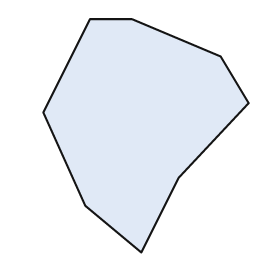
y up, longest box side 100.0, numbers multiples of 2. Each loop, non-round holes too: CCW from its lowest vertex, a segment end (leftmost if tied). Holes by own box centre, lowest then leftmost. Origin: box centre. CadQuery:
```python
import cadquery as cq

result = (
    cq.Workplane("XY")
    .moveTo(-2.0, -50.0)
    .lineTo(14.0, -18.0)
    .lineTo(44.0, 14.0)
    .lineTo(32.0, 34.0)
    .lineTo(-6.0, 50.0)
    .lineTo(-24.0, 50.0)
    .lineTo(-44.0, 10.0)
    .lineTo(-26.0, -30.0)
    .close()
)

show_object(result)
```